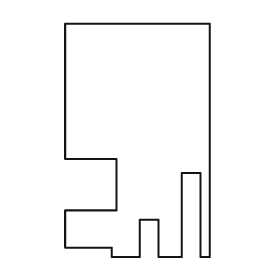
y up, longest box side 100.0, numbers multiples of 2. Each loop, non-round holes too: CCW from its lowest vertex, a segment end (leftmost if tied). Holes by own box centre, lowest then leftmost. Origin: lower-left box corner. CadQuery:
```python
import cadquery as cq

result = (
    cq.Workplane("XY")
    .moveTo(20.0, 0.0)
    .lineTo(32.0, 0.0)
    .lineTo(32.0, 16.0)
    .lineTo(40.0, 16.0)
    .lineTo(40.0, 0.0)
    .lineTo(50.0, 0.0)
    .lineTo(50.0, 36.0)
    .lineTo(58.0, 36.0)
    .lineTo(58.0, 0.0)
    .lineTo(62.0, 0.0)
    .lineTo(62.0, 100.0)
    .lineTo(0.0, 100.0)
    .lineTo(0.0, 42.0)
    .lineTo(22.0, 42.0)
    .lineTo(22.0, 20.0)
    .lineTo(0.0, 20.0)
    .lineTo(0.0, 4.0)
    .lineTo(20.0, 4.0)
    .close()
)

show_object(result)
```